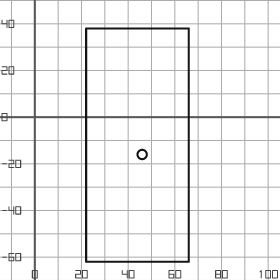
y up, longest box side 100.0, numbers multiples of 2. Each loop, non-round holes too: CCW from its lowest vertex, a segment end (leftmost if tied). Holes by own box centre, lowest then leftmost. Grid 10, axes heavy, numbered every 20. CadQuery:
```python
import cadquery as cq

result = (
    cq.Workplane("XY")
    .moveTo(22.0, -62.0)
    .lineTo(66.0, -62.0)
    .lineTo(66.0, 38.0)
    .lineTo(22.0, 38.0)
    .close()
    .moveTo(46.0, -16.0)
    .circle(2.0)
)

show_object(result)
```